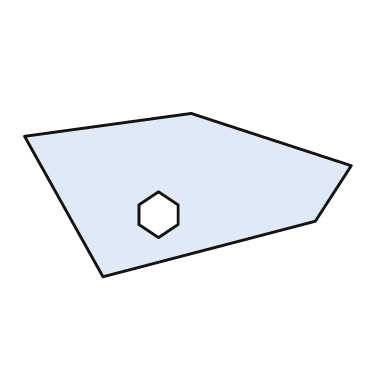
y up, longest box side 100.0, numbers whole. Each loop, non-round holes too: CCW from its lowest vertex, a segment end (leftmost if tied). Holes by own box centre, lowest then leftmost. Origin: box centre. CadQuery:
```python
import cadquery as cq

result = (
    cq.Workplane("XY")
    .moveTo(-26.0, -25.0)
    .lineTo(39.0, -8.0)
    .lineTo(50.0, 9.0)
    .lineTo(1.0, 25.0)
    .lineTo(-50.0, 18.0)
    .close()
    .moveTo(-9.0, -13.0)
    .lineTo(-3.0, -9.0)
    .lineTo(-3.0, -3.0)
    .lineTo(-9.0, 1.0)
    .lineTo(-15.0, -3.0)
    .lineTo(-15.0, -9.0)
    .close()
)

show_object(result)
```